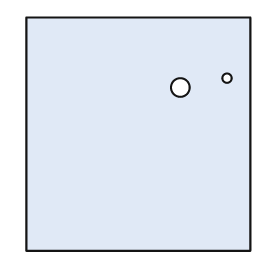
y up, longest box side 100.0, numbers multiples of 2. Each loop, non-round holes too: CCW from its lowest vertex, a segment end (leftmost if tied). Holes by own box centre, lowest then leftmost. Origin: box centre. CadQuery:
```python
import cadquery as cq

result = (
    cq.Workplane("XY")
    .moveTo(-48.0, -50.0)
    .lineTo(48.0, -50.0)
    .lineTo(48.0, 50.0)
    .lineTo(-48.0, 50.0)
    .close()
    .moveTo(18.0, 20.0)
    .circle(4.0)
    .moveTo(38.0, 24.0)
    .circle(2.0)
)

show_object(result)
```